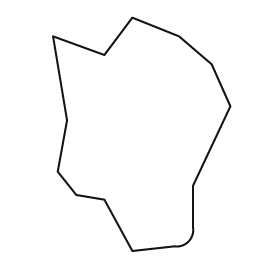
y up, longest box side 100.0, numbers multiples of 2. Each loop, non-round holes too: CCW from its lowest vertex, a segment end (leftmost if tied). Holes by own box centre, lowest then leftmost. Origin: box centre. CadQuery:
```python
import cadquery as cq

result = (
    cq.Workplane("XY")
    .moveTo(-4.0, -50.0)
    .lineTo(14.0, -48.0)
    .threePointArc((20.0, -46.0), (22.0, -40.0))
    .lineTo(22.0, -22.0)
    .lineTo(38.0, 12.0)
    .lineTo(30.0, 30.0)
    .lineTo(16.0, 42.0)
    .lineTo(-4.0, 50.0)
    .lineTo(-16.0, 34.0)
    .lineTo(-38.0, 42.0)
    .lineTo(-32.0, 6.0)
    .lineTo(-36.0, -16.0)
    .lineTo(-28.0, -26.0)
    .lineTo(-16.0, -28.0)
    .close()
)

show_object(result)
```